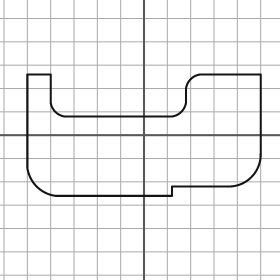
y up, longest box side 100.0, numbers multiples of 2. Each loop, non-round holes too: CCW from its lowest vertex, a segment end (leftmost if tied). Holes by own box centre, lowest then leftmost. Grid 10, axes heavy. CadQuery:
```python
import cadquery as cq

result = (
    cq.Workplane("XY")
    .moveTo(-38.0, -26.0)
    .lineTo(12.0, -26.0)
    .lineTo(12.0, -22.0)
    .lineTo(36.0, -22.0)
    .threePointArc((46.0, -18.0), (50.0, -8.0))
    .lineTo(50.0, 26.0)
    .lineTo(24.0, 26.0)
    .threePointArc((20.0, 24.0), (18.0, 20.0))
    .lineTo(18.0, 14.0)
    .threePointArc((16.0, 10.0), (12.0, 8.0))
    .lineTo(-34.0, 8.0)
    .threePointArc((-38.0, 10.0), (-40.0, 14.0))
    .lineTo(-40.0, 26.0)
    .lineTo(-50.0, 26.0)
    .lineTo(-50.0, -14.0)
    .threePointArc((-46.0, -22.0), (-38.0, -26.0))
    .close()
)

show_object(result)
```